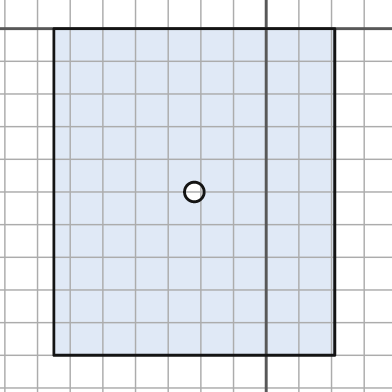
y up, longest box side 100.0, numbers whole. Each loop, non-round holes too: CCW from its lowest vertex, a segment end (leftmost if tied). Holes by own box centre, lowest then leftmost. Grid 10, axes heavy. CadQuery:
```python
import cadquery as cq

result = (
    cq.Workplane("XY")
    .moveTo(-65.0, -100.0)
    .lineTo(21.0, -100.0)
    .lineTo(21.0, 0.0)
    .lineTo(-65.0, 0.0)
    .close()
    .moveTo(-22.0, -50.0)
    .circle(3.0)
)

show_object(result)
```